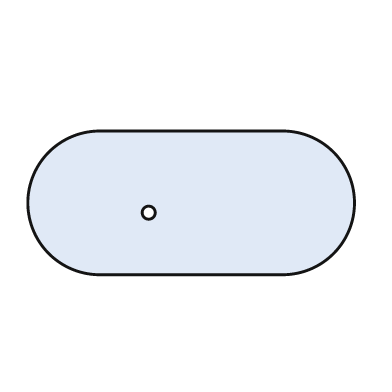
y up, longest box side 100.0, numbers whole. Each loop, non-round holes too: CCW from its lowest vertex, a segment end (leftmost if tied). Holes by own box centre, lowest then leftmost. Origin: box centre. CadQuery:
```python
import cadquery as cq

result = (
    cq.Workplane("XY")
    .moveTo(-28.0, -22.0)
    .lineTo(28.0, -22.0)
    .threePointArc((50.0, 0.0), (28.0, 22.0))
    .lineTo(-28.0, 22.0)
    .threePointArc((-50.0, 0.0), (-28.0, -22.0))
    .close()
    .moveTo(-13.0, -3.0)
    .circle(2.0)
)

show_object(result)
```